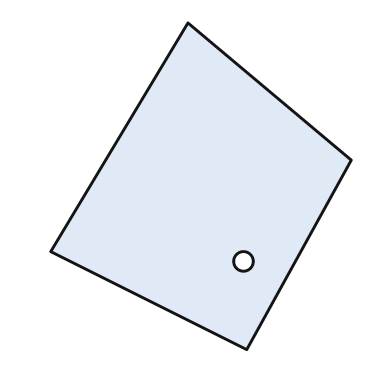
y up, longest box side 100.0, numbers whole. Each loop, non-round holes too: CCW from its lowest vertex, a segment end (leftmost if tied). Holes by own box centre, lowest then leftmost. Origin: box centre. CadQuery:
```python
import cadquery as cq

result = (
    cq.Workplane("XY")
    .moveTo(14.0, -50.0)
    .lineTo(46.0, 8.0)
    .lineTo(-4.0, 50.0)
    .lineTo(-46.0, -20.0)
    .close()
    .moveTo(13.0, -23.0)
    .circle(3.0)
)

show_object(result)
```